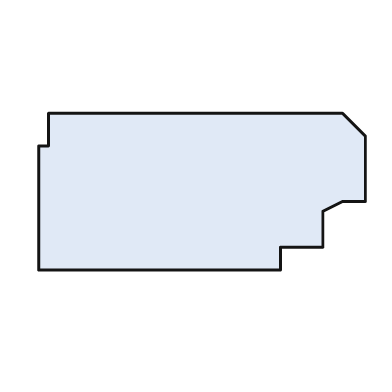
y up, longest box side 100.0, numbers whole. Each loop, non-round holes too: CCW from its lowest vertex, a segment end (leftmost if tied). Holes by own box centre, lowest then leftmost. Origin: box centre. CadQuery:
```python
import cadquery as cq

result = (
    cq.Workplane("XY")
    .moveTo(-50.0, -24.0)
    .lineTo(24.0, -24.0)
    .lineTo(24.0, -17.0)
    .lineTo(37.0, -17.0)
    .lineTo(37.0, -6.0)
    .lineTo(43.0, -3.0)
    .lineTo(50.0, -3.0)
    .lineTo(50.0, 17.0)
    .lineTo(43.0, 24.0)
    .lineTo(-47.0, 24.0)
    .lineTo(-47.0, 14.0)
    .lineTo(-50.0, 14.0)
    .close()
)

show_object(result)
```